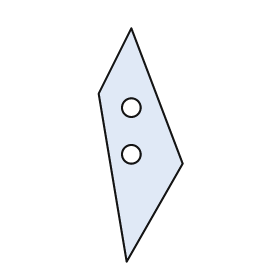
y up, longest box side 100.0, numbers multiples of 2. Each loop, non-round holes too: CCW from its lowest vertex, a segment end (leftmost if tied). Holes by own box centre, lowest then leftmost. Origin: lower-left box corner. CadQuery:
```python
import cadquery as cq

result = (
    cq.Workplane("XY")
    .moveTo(12.0, 0.0)
    .lineTo(36.0, 42.0)
    .lineTo(14.0, 100.0)
    .lineTo(0.0, 72.0)
    .close()
    .moveTo(14.0, 46.0)
    .circle(4.0)
    .moveTo(14.0, 66.0)
    .circle(4.0)
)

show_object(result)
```